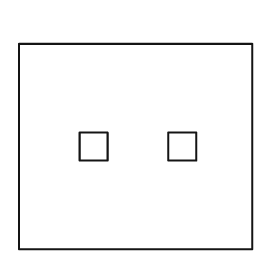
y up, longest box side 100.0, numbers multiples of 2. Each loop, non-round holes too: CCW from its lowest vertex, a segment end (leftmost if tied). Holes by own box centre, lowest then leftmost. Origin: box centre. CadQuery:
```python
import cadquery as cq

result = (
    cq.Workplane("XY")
    .moveTo(-50.0, -44.0)
    .lineTo(50.0, -44.0)
    .lineTo(50.0, 44.0)
    .lineTo(-50.0, 44.0)
    .close()
    .moveTo(-24.0, -6.0)
    .lineTo(-12.0, -6.0)
    .lineTo(-12.0, 6.0)
    .lineTo(-24.0, 6.0)
    .close()
    .moveTo(14.0, -6.0)
    .lineTo(26.0, -6.0)
    .lineTo(26.0, 6.0)
    .lineTo(14.0, 6.0)
    .close()
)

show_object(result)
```